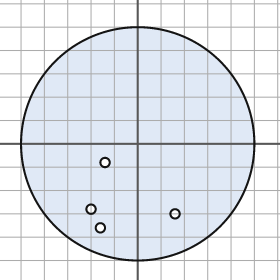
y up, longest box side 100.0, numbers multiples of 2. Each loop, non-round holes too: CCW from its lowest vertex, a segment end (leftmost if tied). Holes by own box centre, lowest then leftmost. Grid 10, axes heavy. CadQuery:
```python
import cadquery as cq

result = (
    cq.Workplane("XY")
    .moveTo(0.0, 0.0)
    .circle(50.0)
    .moveTo(-16.0, -36.0)
    .circle(2.0)
    .moveTo(16.0, -30.0)
    .circle(2.0)
    .moveTo(-20.0, -28.0)
    .circle(2.0)
    .moveTo(-14.0, -8.0)
    .circle(2.0)
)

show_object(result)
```